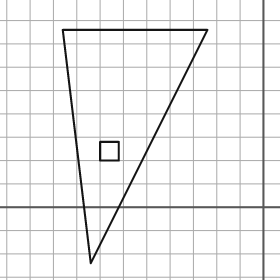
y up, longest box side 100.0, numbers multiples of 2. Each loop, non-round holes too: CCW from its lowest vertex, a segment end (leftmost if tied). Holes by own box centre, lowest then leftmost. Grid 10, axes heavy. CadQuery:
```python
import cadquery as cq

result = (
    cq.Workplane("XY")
    .moveTo(-74.0, -24.0)
    .lineTo(-24.0, 76.0)
    .lineTo(-86.0, 76.0)
    .close()
    .moveTo(-70.0, 20.0)
    .lineTo(-62.0, 20.0)
    .lineTo(-62.0, 28.0)
    .lineTo(-70.0, 28.0)
    .close()
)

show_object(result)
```